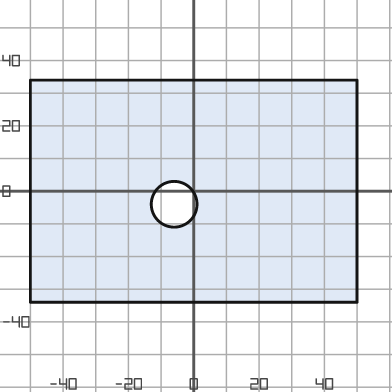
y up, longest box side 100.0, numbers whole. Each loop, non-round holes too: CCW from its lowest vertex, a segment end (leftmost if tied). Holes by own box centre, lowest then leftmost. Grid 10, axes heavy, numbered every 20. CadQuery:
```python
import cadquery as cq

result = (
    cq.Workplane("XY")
    .moveTo(-50.0, -34.0)
    .lineTo(50.0, -34.0)
    .lineTo(50.0, 34.0)
    .lineTo(-50.0, 34.0)
    .close()
    .moveTo(-6.0, -4.0)
    .circle(7.0)
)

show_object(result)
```